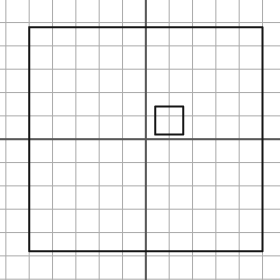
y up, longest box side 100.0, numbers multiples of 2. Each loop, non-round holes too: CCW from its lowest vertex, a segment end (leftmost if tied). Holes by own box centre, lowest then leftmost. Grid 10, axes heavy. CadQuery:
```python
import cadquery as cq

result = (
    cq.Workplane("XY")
    .moveTo(-50.0, -48.0)
    .lineTo(50.0, -48.0)
    .lineTo(50.0, 48.0)
    .lineTo(-50.0, 48.0)
    .close()
    .moveTo(4.0, 2.0)
    .lineTo(16.0, 2.0)
    .lineTo(16.0, 14.0)
    .lineTo(4.0, 14.0)
    .close()
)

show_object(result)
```